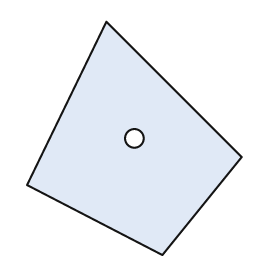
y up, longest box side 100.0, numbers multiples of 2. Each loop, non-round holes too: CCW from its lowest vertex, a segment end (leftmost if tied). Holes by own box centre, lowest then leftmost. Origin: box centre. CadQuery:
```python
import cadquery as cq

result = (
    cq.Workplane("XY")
    .moveTo(12.0, -50.0)
    .lineTo(46.0, -8.0)
    .lineTo(-12.0, 50.0)
    .lineTo(-46.0, -20.0)
    .close()
    .moveTo(0.0, 0.0)
    .circle(4.0)
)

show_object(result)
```